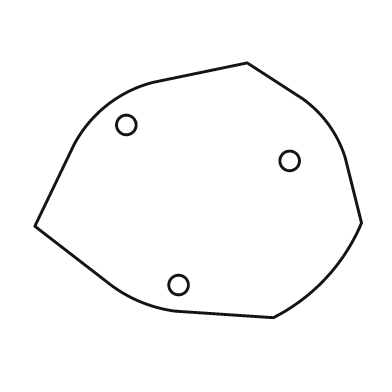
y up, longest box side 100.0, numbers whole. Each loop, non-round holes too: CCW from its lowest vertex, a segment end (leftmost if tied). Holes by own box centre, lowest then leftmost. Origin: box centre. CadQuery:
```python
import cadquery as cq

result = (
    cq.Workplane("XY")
    .moveTo(23.0, -39.0)
    .threePointArc((39.0, -27.0), (50.0, -10.0))
    .lineTo(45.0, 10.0)
    .threePointArc((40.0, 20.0), (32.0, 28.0))
    .lineTo(15.0, 39.0)
    .lineTo(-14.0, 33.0)
    .threePointArc((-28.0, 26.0), (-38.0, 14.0))
    .lineTo(-50.0, -11.0)
    .lineTo(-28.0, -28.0)
    .threePointArc((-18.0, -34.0), (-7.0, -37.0))
    .close()
    .moveTo(-6.0, -29.0)
    .circle(3.0)
    .moveTo(28.0, 9.0)
    .circle(3.0)
    .moveTo(-22.0, 20.0)
    .circle(3.0)
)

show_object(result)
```